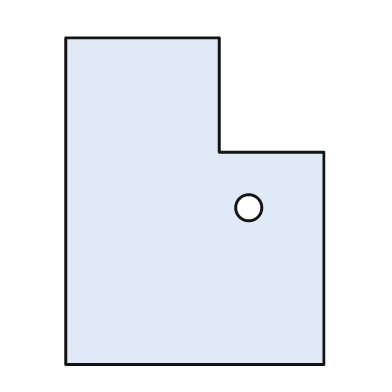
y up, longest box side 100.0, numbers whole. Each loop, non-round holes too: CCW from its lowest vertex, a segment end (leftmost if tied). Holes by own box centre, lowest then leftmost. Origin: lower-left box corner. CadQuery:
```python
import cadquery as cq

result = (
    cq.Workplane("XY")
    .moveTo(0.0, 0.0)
    .lineTo(79.0, 0.0)
    .lineTo(79.0, 65.0)
    .lineTo(47.0, 65.0)
    .lineTo(47.0, 100.0)
    .lineTo(0.0, 100.0)
    .close()
    .moveTo(56.0, 48.0)
    .circle(4.0)
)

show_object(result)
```